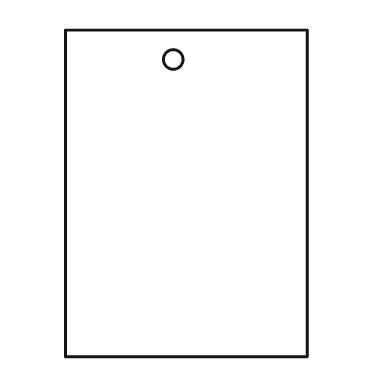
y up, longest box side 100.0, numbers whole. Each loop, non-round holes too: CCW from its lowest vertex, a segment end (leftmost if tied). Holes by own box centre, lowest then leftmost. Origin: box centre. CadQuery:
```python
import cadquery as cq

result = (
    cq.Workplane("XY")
    .moveTo(-37.0, -50.0)
    .lineTo(37.0, -50.0)
    .lineTo(37.0, 50.0)
    .lineTo(-37.0, 50.0)
    .close()
    .moveTo(-4.0, 41.0)
    .circle(3.0)
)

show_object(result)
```